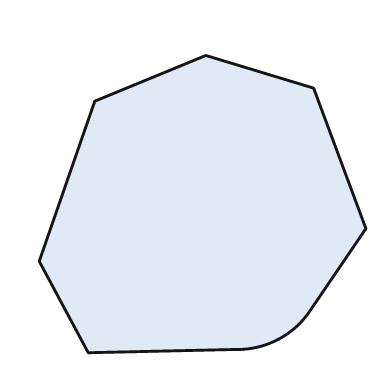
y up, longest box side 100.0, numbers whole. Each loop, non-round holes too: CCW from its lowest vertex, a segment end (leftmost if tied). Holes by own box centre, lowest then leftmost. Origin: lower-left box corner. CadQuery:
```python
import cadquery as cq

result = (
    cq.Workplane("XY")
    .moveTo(15.0, 0.0)
    .lineTo(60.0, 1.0)
    .threePointArc((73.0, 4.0), (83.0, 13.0))
    .lineTo(100.0, 38.0)
    .lineTo(84.0, 81.0)
    .lineTo(51.0, 91.0)
    .lineTo(17.0, 77.0)
    .lineTo(0.0, 28.0)
    .close()
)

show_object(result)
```